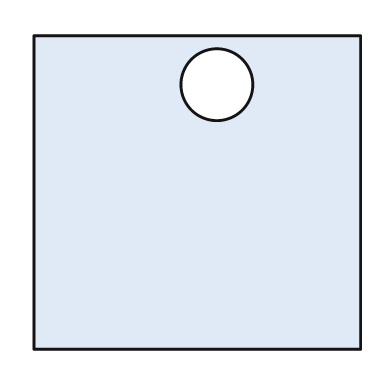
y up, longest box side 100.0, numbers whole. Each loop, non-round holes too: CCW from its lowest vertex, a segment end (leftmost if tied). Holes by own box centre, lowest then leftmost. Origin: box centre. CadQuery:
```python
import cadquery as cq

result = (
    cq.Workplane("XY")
    .moveTo(-50.0, -48.0)
    .lineTo(50.0, -48.0)
    .lineTo(50.0, 48.0)
    .lineTo(-50.0, 48.0)
    .close()
    .moveTo(6.0, 33.0)
    .circle(11.0)
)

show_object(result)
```